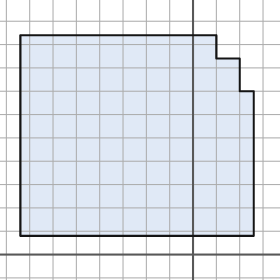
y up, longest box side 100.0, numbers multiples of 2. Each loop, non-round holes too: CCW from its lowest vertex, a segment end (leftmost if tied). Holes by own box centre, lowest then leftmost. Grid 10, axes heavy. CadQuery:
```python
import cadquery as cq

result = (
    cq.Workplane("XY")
    .moveTo(-74.0, 8.0)
    .lineTo(26.0, 8.0)
    .lineTo(26.0, 70.0)
    .lineTo(20.0, 70.0)
    .lineTo(20.0, 84.0)
    .lineTo(10.0, 84.0)
    .lineTo(10.0, 94.0)
    .lineTo(-74.0, 94.0)
    .close()
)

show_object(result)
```